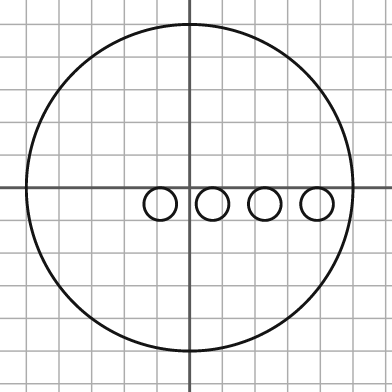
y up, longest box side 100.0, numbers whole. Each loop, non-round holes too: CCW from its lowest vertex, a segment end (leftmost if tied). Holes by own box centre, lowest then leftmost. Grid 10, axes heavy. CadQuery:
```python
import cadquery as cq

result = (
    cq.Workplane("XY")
    .moveTo(0.0, 0.0)
    .circle(50.0)
    .moveTo(-9.0, -5.0)
    .circle(5.0)
    .moveTo(7.0, -5.0)
    .circle(5.0)
    .moveTo(23.0, -5.0)
    .circle(5.0)
    .moveTo(39.0, -5.0)
    .circle(5.0)
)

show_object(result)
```